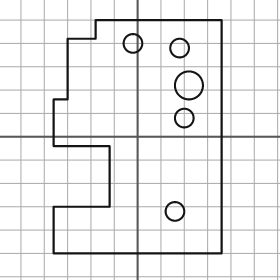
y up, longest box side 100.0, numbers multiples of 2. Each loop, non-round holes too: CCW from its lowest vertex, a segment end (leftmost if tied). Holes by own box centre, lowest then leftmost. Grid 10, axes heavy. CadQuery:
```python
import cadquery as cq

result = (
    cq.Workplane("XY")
    .moveTo(-36.0, -50.0)
    .lineTo(36.0, -50.0)
    .lineTo(36.0, 50.0)
    .lineTo(-18.0, 50.0)
    .lineTo(-18.0, 42.0)
    .lineTo(-30.0, 42.0)
    .lineTo(-30.0, 16.0)
    .lineTo(-36.0, 16.0)
    .lineTo(-36.0, -4.0)
    .lineTo(-12.0, -4.0)
    .lineTo(-12.0, -30.0)
    .lineTo(-36.0, -30.0)
    .close()
    .moveTo(16.0, -32.0)
    .circle(4.0)
    .moveTo(20.0, 8.0)
    .circle(4.0)
    .moveTo(22.0, 22.0)
    .circle(6.0)
    .moveTo(18.0, 38.0)
    .circle(4.0)
    .moveTo(-2.0, 40.0)
    .circle(4.0)
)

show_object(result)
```